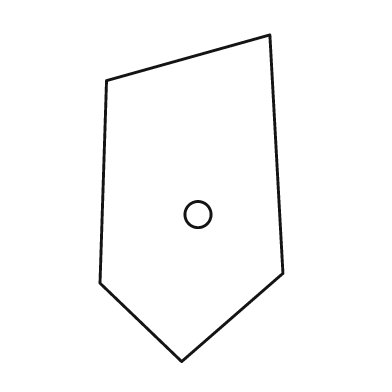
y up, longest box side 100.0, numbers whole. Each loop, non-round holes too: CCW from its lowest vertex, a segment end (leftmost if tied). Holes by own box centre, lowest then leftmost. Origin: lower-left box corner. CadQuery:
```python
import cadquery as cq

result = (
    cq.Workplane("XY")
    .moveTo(25.0, 0.0)
    .lineTo(56.0, 27.0)
    .lineTo(52.0, 100.0)
    .lineTo(2.0, 86.0)
    .lineTo(0.0, 24.0)
    .close()
    .moveTo(30.0, 45.0)
    .circle(4.0)
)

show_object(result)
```